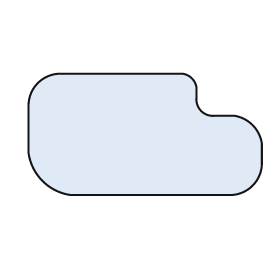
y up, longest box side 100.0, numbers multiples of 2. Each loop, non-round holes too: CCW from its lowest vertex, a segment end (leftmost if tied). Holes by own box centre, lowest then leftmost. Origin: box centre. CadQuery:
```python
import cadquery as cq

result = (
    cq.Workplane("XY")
    .moveTo(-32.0, -26.0)
    .lineTo(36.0, -26.0)
    .threePointArc((46.0, -22.0), (50.0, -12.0))
    .lineTo(50.0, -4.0)
    .threePointArc((46.0, 4.0), (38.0, 8.0))
    .lineTo(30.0, 8.0)
    .threePointArc((24.0, 10.0), (22.0, 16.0))
    .lineTo(22.0, 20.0)
    .threePointArc((20.0, 24.0), (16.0, 26.0))
    .lineTo(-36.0, 26.0)
    .threePointArc((-46.0, 22.0), (-50.0, 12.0))
    .lineTo(-50.0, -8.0)
    .threePointArc((-44.0, -20.0), (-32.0, -26.0))
    .close()
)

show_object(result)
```